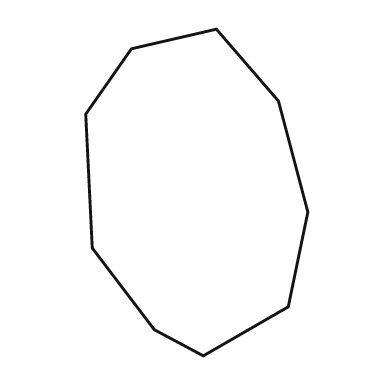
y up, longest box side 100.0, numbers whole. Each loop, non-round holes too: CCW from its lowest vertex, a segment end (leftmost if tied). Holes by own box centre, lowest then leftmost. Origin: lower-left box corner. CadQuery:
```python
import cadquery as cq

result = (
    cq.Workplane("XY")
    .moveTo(36.0, 0.0)
    .lineTo(62.0, 15.0)
    .lineTo(68.0, 44.0)
    .lineTo(59.0, 78.0)
    .lineTo(40.0, 100.0)
    .lineTo(14.0, 94.0)
    .lineTo(0.0, 74.0)
    .lineTo(2.0, 33.0)
    .lineTo(21.0, 8.0)
    .close()
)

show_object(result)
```